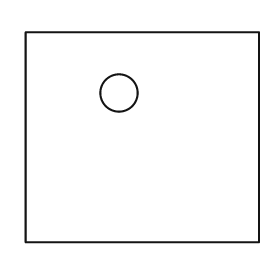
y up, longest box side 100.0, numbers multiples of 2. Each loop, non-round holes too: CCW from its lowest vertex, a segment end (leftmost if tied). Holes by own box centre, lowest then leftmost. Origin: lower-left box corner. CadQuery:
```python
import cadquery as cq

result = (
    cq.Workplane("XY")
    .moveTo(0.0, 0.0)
    .lineTo(100.0, 0.0)
    .lineTo(100.0, 90.0)
    .lineTo(0.0, 90.0)
    .close()
    .moveTo(40.0, 64.0)
    .circle(8.0)
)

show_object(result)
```